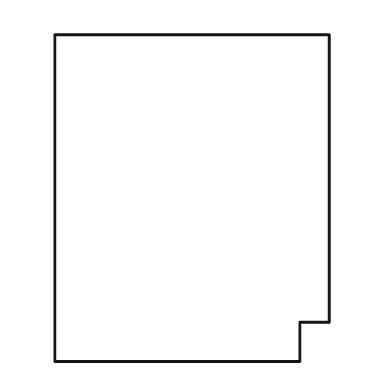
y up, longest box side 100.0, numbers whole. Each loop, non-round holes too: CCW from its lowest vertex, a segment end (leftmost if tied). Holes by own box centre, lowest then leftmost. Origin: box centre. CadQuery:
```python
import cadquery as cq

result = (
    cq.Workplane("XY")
    .moveTo(-42.0, -50.0)
    .lineTo(33.0, -50.0)
    .lineTo(33.0, -38.0)
    .lineTo(42.0, -38.0)
    .lineTo(42.0, 50.0)
    .lineTo(-42.0, 50.0)
    .close()
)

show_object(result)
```